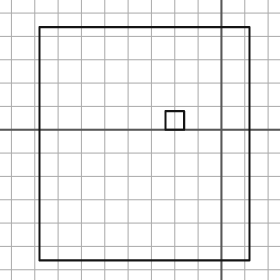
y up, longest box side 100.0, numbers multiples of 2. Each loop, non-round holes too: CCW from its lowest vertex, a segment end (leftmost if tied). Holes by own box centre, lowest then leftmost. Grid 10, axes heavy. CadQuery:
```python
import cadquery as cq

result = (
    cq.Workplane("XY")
    .moveTo(-78.0, -56.0)
    .lineTo(12.0, -56.0)
    .lineTo(12.0, 44.0)
    .lineTo(-78.0, 44.0)
    .close()
    .moveTo(-24.0, 0.0)
    .lineTo(-16.0, 0.0)
    .lineTo(-16.0, 8.0)
    .lineTo(-24.0, 8.0)
    .close()
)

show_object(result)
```